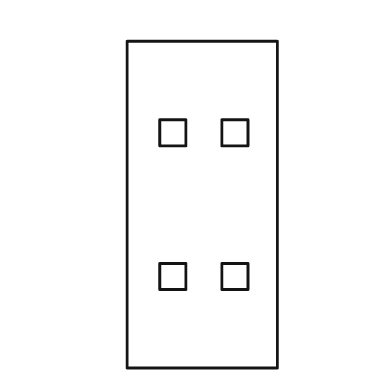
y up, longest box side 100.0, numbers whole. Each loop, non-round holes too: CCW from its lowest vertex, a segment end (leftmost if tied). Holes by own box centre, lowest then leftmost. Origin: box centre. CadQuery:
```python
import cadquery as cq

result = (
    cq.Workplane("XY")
    .moveTo(-23.0, -50.0)
    .lineTo(23.0, -50.0)
    .lineTo(23.0, 50.0)
    .lineTo(-23.0, 50.0)
    .close()
    .moveTo(-13.0, -26.0)
    .lineTo(-5.0, -26.0)
    .lineTo(-5.0, -18.0)
    .lineTo(-13.0, -18.0)
    .close()
    .moveTo(6.0, -26.0)
    .lineTo(14.0, -26.0)
    .lineTo(14.0, -18.0)
    .lineTo(6.0, -18.0)
    .close()
    .moveTo(-13.0, 18.0)
    .lineTo(-5.0, 18.0)
    .lineTo(-5.0, 26.0)
    .lineTo(-13.0, 26.0)
    .close()
    .moveTo(6.0, 18.0)
    .lineTo(14.0, 18.0)
    .lineTo(14.0, 26.0)
    .lineTo(6.0, 26.0)
    .close()
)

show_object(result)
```